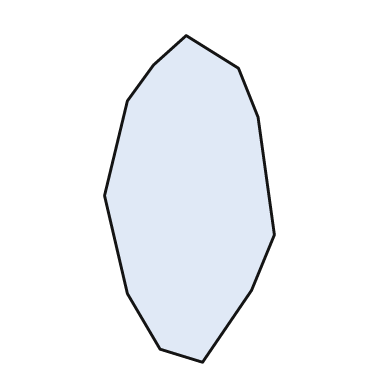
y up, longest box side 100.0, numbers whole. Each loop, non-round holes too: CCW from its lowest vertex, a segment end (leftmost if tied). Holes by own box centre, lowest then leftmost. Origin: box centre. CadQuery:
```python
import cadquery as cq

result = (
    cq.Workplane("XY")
    .moveTo(4.0, -50.0)
    .lineTo(19.0, -28.0)
    .lineTo(26.0, -11.0)
    .lineTo(21.0, 25.0)
    .lineTo(15.0, 40.0)
    .lineTo(-1.0, 50.0)
    .lineTo(-11.0, 41.0)
    .lineTo(-19.0, 30.0)
    .lineTo(-26.0, 1.0)
    .lineTo(-19.0, -29.0)
    .lineTo(-9.0, -46.0)
    .close()
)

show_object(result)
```